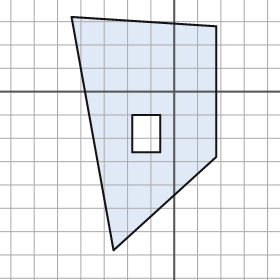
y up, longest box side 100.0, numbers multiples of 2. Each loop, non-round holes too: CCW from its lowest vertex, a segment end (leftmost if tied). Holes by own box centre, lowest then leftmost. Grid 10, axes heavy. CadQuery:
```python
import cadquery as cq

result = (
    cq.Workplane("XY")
    .moveTo(-26.0, -68.0)
    .lineTo(18.0, -28.0)
    .lineTo(18.0, 28.0)
    .lineTo(-44.0, 32.0)
    .close()
    .moveTo(-18.0, -26.0)
    .lineTo(-6.0, -26.0)
    .lineTo(-6.0, -10.0)
    .lineTo(-18.0, -10.0)
    .close()
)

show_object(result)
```